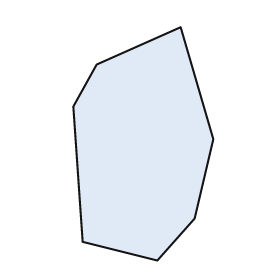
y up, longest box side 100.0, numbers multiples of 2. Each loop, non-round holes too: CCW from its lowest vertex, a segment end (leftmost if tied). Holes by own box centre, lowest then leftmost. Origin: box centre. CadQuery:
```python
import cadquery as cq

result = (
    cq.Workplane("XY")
    .moveTo(6.0, -50.0)
    .lineTo(22.0, -32.0)
    .lineTo(30.0, 2.0)
    .lineTo(16.0, 50.0)
    .lineTo(-20.0, 34.0)
    .lineTo(-30.0, 16.0)
    .lineTo(-26.0, -42.0)
    .close()
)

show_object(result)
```